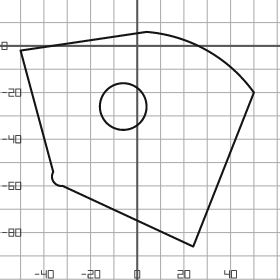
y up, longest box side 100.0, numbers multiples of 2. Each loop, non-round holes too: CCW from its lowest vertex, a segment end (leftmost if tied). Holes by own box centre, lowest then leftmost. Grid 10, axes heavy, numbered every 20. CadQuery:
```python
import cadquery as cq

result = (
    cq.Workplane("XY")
    .moveTo(24.0, -86.0)
    .lineTo(50.0, -20.0)
    .threePointArc((30.0, -2.0), (4.0, 6.0))
    .lineTo(-50.0, -2.0)
    .lineTo(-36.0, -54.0)
    .threePointArc((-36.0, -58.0), (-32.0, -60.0))
    .close()
    .moveTo(-6.0, -26.0)
    .circle(10.0)
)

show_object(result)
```